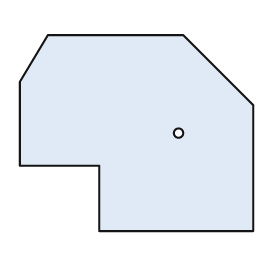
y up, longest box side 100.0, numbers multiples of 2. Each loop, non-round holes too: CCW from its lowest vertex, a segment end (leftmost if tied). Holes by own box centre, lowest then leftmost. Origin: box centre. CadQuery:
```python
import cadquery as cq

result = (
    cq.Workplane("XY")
    .moveTo(-16.0, -42.0)
    .lineTo(50.0, -42.0)
    .lineTo(50.0, 12.0)
    .lineTo(20.0, 42.0)
    .lineTo(-38.0, 42.0)
    .lineTo(-50.0, 22.0)
    .lineTo(-50.0, -14.0)
    .lineTo(-16.0, -14.0)
    .close()
    .moveTo(18.0, 0.0)
    .circle(2.0)
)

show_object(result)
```